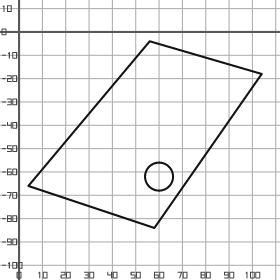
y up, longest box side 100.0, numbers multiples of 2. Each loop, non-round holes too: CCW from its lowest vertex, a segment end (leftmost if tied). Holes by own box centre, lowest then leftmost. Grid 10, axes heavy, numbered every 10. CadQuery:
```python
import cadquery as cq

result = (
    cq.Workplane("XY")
    .moveTo(58.0, -84.0)
    .lineTo(104.0, -18.0)
    .lineTo(56.0, -4.0)
    .lineTo(4.0, -66.0)
    .close()
    .moveTo(60.0, -62.0)
    .circle(6.0)
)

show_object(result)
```